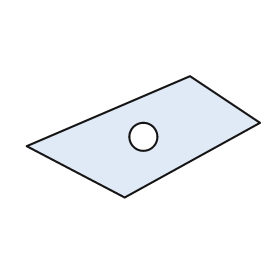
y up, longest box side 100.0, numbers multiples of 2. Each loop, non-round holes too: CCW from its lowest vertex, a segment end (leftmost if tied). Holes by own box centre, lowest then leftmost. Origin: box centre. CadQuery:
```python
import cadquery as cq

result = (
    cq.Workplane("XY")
    .moveTo(-8.0, -26.0)
    .lineTo(50.0, 6.0)
    .lineTo(20.0, 26.0)
    .lineTo(-50.0, -4.0)
    .close()
    .moveTo(0.0, 0.0)
    .circle(6.0)
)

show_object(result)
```